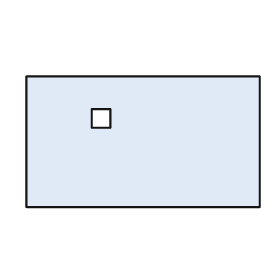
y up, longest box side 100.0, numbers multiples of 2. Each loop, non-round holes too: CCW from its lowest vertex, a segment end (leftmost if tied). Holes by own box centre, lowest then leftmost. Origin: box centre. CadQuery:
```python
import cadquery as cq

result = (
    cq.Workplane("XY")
    .moveTo(-50.0, -28.0)
    .lineTo(50.0, -28.0)
    .lineTo(50.0, 28.0)
    .lineTo(-50.0, 28.0)
    .close()
    .moveTo(-22.0, 6.0)
    .lineTo(-14.0, 6.0)
    .lineTo(-14.0, 14.0)
    .lineTo(-22.0, 14.0)
    .close()
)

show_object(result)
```